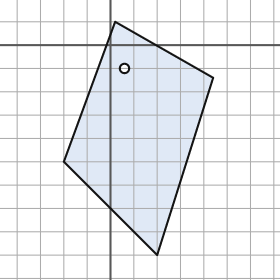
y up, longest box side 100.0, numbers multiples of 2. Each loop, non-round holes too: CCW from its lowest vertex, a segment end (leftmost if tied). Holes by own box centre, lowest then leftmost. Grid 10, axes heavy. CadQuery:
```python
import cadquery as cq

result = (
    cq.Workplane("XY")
    .moveTo(20.0, -90.0)
    .lineTo(44.0, -14.0)
    .lineTo(2.0, 10.0)
    .lineTo(-20.0, -50.0)
    .close()
    .moveTo(6.0, -10.0)
    .circle(2.0)
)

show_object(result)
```